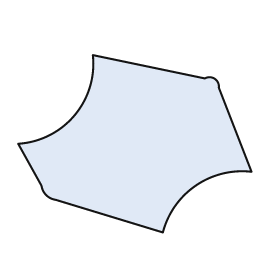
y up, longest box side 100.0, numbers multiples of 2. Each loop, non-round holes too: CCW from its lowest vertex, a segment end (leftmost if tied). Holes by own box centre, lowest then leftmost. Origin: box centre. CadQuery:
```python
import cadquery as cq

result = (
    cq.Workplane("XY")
    .moveTo(12.0, -38.0)
    .threePointArc((26.0, -18.0), (50.0, -12.0))
    .lineTo(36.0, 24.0)
    .threePointArc((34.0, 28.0), (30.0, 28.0))
    .lineTo(-18.0, 38.0)
    .threePointArc((-26.0, 12.0), (-50.0, 0.0))
    .lineTo(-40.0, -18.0)
    .threePointArc((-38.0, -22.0), (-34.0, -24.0))
    .close()
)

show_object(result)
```